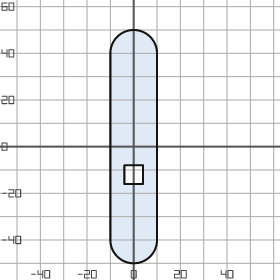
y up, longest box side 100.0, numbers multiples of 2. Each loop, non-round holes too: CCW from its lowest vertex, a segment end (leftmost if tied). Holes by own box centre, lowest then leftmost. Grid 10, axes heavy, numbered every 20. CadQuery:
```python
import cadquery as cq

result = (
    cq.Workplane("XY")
    .moveTo(-10.0, -40.0)
    .threePointArc((0.0, -50.0), (10.0, -40.0))
    .lineTo(10.0, 40.0)
    .threePointArc((0.0, 50.0), (-10.0, 40.0))
    .close()
    .moveTo(-4.0, -16.0)
    .lineTo(4.0, -16.0)
    .lineTo(4.0, -8.0)
    .lineTo(-4.0, -8.0)
    .close()
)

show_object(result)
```